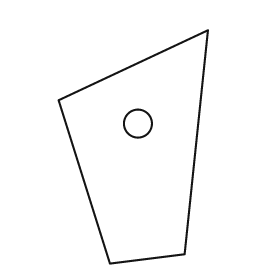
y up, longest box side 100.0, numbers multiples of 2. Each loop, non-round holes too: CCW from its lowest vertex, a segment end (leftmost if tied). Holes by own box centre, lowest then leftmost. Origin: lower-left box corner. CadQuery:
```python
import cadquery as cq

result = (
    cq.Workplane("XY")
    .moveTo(22.0, 0.0)
    .lineTo(54.0, 4.0)
    .lineTo(64.0, 100.0)
    .lineTo(0.0, 70.0)
    .close()
    .moveTo(34.0, 60.0)
    .circle(6.0)
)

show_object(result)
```